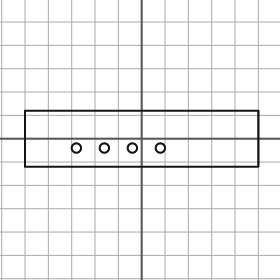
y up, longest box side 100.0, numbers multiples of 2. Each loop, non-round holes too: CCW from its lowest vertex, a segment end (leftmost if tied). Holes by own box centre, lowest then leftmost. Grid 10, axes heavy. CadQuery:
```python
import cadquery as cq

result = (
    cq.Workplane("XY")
    .moveTo(-50.0, -12.0)
    .lineTo(50.0, -12.0)
    .lineTo(50.0, 12.0)
    .lineTo(-50.0, 12.0)
    .close()
    .moveTo(-28.0, -4.0)
    .circle(2.0)
    .moveTo(-16.0, -4.0)
    .circle(2.0)
    .moveTo(-4.0, -4.0)
    .circle(2.0)
    .moveTo(8.0, -4.0)
    .circle(2.0)
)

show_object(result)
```